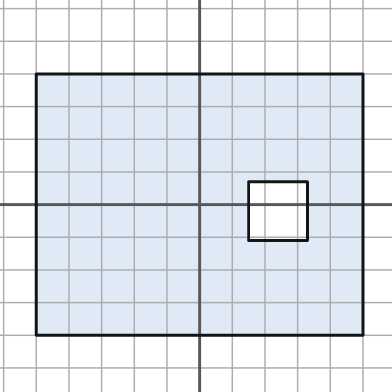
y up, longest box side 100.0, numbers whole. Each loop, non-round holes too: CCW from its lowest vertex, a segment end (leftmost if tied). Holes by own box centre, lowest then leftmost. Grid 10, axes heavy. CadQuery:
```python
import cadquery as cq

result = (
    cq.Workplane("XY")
    .moveTo(-50.0, -40.0)
    .lineTo(50.0, -40.0)
    .lineTo(50.0, 40.0)
    .lineTo(-50.0, 40.0)
    .close()
    .moveTo(15.0, -11.0)
    .lineTo(33.0, -11.0)
    .lineTo(33.0, 7.0)
    .lineTo(15.0, 7.0)
    .close()
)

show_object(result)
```